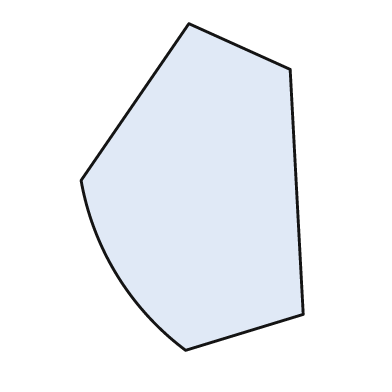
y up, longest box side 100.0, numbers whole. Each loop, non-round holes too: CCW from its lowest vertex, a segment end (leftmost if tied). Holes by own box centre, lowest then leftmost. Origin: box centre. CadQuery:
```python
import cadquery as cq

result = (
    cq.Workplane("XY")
    .moveTo(-2.0, -50.0)
    .lineTo(34.0, -39.0)
    .lineTo(30.0, 36.0)
    .lineTo(-1.0, 50.0)
    .lineTo(-34.0, 2.0)
    .threePointArc((-23.0, -27.0), (-2.0, -50.0))
    .close()
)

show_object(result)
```